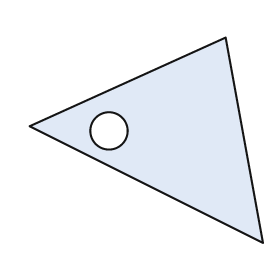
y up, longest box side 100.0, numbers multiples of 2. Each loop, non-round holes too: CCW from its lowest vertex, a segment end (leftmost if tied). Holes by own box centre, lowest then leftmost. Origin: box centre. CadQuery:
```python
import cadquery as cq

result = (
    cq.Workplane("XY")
    .moveTo(50.0, -44.0)
    .lineTo(34.0, 44.0)
    .lineTo(-50.0, 6.0)
    .close()
    .moveTo(-16.0, 4.0)
    .circle(8.0)
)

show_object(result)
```